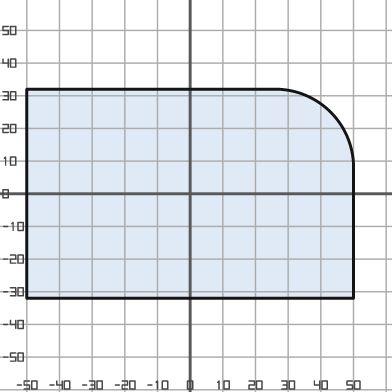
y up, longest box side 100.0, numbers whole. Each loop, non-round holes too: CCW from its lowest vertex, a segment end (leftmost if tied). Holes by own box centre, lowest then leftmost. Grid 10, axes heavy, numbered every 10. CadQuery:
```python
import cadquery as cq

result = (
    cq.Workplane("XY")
    .moveTo(-50.0, -32.0)
    .lineTo(50.0, -32.0)
    .lineTo(50.0, 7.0)
    .threePointArc((43.0, 25.0), (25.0, 32.0))
    .lineTo(-50.0, 32.0)
    .close()
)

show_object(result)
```